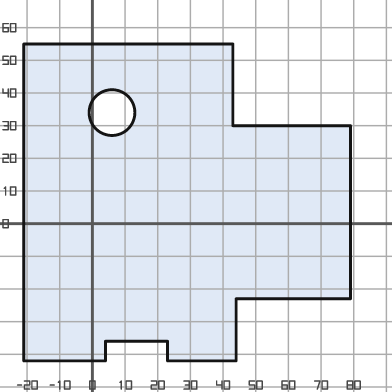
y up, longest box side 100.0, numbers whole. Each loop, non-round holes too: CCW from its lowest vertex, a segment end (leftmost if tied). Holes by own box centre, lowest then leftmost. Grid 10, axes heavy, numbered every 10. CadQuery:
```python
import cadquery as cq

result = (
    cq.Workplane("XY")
    .moveTo(-21.0, -42.0)
    .lineTo(4.0, -42.0)
    .lineTo(4.0, -36.0)
    .lineTo(23.0, -36.0)
    .lineTo(23.0, -42.0)
    .lineTo(44.0, -42.0)
    .lineTo(44.0, -23.0)
    .lineTo(79.0, -23.0)
    .lineTo(79.0, 30.0)
    .lineTo(43.0, 30.0)
    .lineTo(43.0, 55.0)
    .lineTo(-21.0, 55.0)
    .close()
    .moveTo(6.0, 34.0)
    .circle(7.0)
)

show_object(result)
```